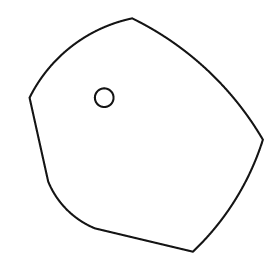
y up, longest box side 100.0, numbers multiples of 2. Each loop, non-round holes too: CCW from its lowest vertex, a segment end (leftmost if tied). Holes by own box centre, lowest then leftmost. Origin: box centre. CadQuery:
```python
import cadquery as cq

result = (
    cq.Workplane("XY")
    .moveTo(20.0, -50.0)
    .threePointArc((38.0, -28.0), (50.0, -2.0))
    .threePointArc((26.0, 28.0), (-6.0, 50.0))
    .threePointArc((-32.0, 38.0), (-50.0, 16.0))
    .lineTo(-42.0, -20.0)
    .threePointArc((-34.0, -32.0), (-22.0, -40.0))
    .close()
    .moveTo(-18.0, 16.0)
    .circle(4.0)
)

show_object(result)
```